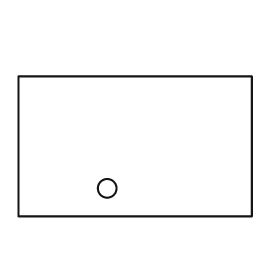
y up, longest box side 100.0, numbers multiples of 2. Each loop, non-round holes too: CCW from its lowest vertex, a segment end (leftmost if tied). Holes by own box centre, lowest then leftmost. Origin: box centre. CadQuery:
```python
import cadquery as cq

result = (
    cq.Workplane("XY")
    .moveTo(-50.0, -30.0)
    .lineTo(50.0, -30.0)
    .lineTo(50.0, 30.0)
    .lineTo(-50.0, 30.0)
    .close()
    .moveTo(-12.0, -18.0)
    .circle(4.0)
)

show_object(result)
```